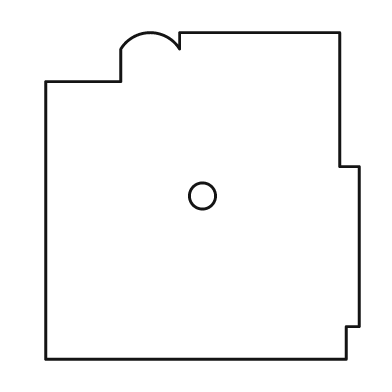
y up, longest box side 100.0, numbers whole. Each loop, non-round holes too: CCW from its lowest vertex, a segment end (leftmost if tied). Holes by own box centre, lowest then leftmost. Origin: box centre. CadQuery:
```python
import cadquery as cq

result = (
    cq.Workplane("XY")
    .moveTo(-48.0, -50.0)
    .lineTo(44.0, -50.0)
    .lineTo(44.0, -40.0)
    .lineTo(48.0, -40.0)
    .lineTo(48.0, 9.0)
    .lineTo(42.0, 9.0)
    .lineTo(42.0, 50.0)
    .lineTo(-7.0, 50.0)
    .lineTo(-7.0, 45.0)
    .threePointArc((-16.0, 50.0), (-25.0, 45.0))
    .lineTo(-25.0, 35.0)
    .lineTo(-48.0, 35.0)
    .close()
    .moveTo(0.0, 0.0)
    .circle(4.0)
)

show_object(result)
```